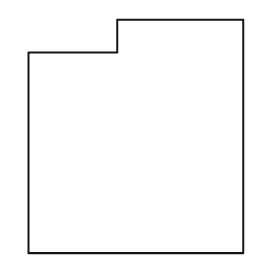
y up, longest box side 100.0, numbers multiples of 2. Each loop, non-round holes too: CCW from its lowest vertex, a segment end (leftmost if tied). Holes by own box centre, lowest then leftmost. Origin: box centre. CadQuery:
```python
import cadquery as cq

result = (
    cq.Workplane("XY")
    .moveTo(-46.0, -50.0)
    .lineTo(46.0, -50.0)
    .lineTo(46.0, 50.0)
    .lineTo(-8.0, 50.0)
    .lineTo(-8.0, 36.0)
    .lineTo(-46.0, 36.0)
    .close()
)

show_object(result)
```